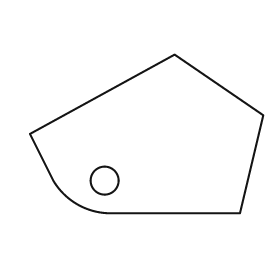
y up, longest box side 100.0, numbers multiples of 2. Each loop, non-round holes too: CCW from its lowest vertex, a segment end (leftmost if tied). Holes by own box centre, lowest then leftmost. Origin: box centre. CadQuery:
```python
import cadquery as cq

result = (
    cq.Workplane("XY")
    .moveTo(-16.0, -34.0)
    .lineTo(40.0, -34.0)
    .lineTo(50.0, 8.0)
    .lineTo(12.0, 34.0)
    .lineTo(-50.0, 0.0)
    .lineTo(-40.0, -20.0)
    .threePointArc((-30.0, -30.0), (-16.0, -34.0))
    .close()
    .moveTo(-18.0, -20.0)
    .circle(6.0)
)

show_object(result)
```